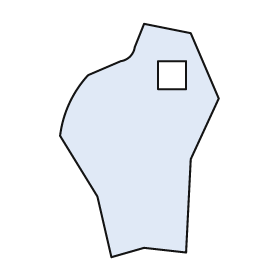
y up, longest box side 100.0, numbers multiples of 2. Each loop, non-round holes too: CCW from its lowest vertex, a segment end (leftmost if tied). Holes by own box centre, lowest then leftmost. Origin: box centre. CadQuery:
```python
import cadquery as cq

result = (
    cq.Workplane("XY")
    .moveTo(-12.0, -50.0)
    .lineTo(2.0, -46.0)
    .lineTo(20.0, -48.0)
    .lineTo(22.0, -8.0)
    .lineTo(34.0, 18.0)
    .lineTo(22.0, 46.0)
    .lineTo(2.0, 50.0)
    .lineTo(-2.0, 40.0)
    .threePointArc((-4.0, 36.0), (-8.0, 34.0))
    .lineTo(-22.0, 28.0)
    .threePointArc((-30.0, 16.0), (-34.0, 2.0))
    .lineTo(-18.0, -24.0)
    .close()
    .moveTo(8.0, 22.0)
    .lineTo(20.0, 22.0)
    .lineTo(20.0, 34.0)
    .lineTo(8.0, 34.0)
    .close()
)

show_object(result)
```